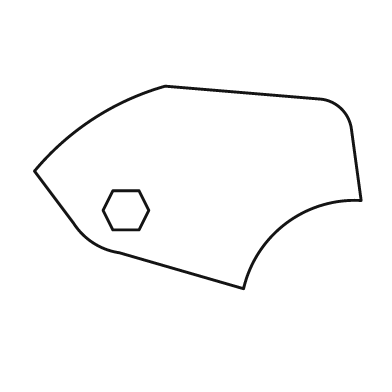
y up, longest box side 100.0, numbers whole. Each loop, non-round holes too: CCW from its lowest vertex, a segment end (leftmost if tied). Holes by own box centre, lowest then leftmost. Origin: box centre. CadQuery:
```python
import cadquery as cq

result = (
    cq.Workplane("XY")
    .moveTo(14.0, -31.0)
    .threePointArc((27.0, -11.0), (50.0, -4.0))
    .lineTo(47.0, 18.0)
    .threePointArc((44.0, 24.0), (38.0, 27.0))
    .lineTo(-10.0, 31.0)
    .threePointArc((-32.0, 21.0), (-50.0, 5.0))
    .lineTo(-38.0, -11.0)
    .threePointArc((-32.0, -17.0), (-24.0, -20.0))
    .close()
    .moveTo(-26.0, -13.0)
    .lineTo(-18.0, -13.0)
    .lineTo(-15.0, -7.0)
    .lineTo(-18.0, -1.0)
    .lineTo(-26.0, -1.0)
    .lineTo(-29.0, -7.0)
    .close()
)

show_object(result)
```